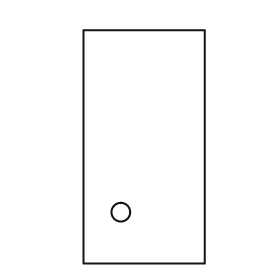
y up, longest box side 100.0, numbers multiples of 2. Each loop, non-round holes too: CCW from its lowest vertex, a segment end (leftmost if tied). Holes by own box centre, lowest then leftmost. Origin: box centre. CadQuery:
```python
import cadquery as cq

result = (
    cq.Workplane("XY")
    .moveTo(-26.0, -50.0)
    .lineTo(26.0, -50.0)
    .lineTo(26.0, 50.0)
    .lineTo(-26.0, 50.0)
    .close()
    .moveTo(-10.0, -28.0)
    .circle(4.0)
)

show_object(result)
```